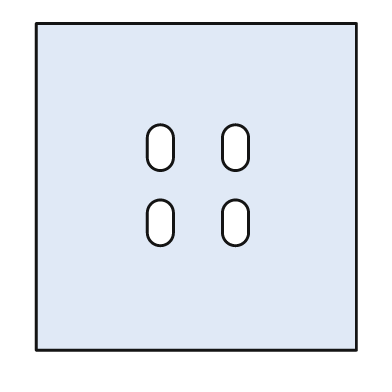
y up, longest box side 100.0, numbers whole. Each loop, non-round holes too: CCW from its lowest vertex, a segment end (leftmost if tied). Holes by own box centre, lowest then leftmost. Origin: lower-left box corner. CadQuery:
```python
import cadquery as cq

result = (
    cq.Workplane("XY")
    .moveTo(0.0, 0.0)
    .lineTo(98.0, 0.0)
    .lineTo(98.0, 100.0)
    .lineTo(0.0, 100.0)
    .close()
    .moveTo(34.0, 36.0)
    .threePointArc((38.0, 32.0), (42.0, 36.0))
    .lineTo(42.0, 42.0)
    .threePointArc((38.0, 46.0), (34.0, 42.0))
    .close()
    .moveTo(57.0, 36.0)
    .threePointArc((61.0, 32.0), (65.0, 36.0))
    .lineTo(65.0, 42.0)
    .threePointArc((61.0, 46.0), (57.0, 42.0))
    .close()
    .moveTo(34.0, 59.0)
    .threePointArc((38.0, 55.0), (42.0, 59.0))
    .lineTo(42.0, 65.0)
    .threePointArc((38.0, 69.0), (34.0, 65.0))
    .close()
    .moveTo(57.0, 59.0)
    .threePointArc((61.0, 55.0), (65.0, 59.0))
    .lineTo(65.0, 65.0)
    .threePointArc((61.0, 69.0), (57.0, 65.0))
    .close()
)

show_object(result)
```